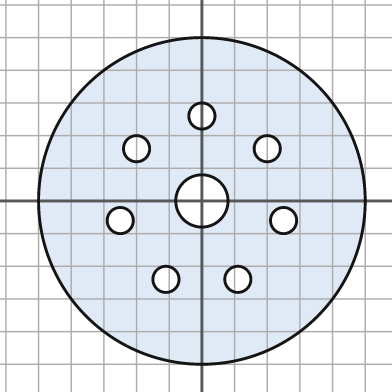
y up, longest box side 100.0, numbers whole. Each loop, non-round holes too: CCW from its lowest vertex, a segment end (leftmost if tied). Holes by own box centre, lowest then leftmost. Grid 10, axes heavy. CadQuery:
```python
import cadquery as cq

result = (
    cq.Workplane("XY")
    .moveTo(0.0, 0.0)
    .circle(50.0)
    .moveTo(-11.0, -24.0)
    .circle(4.0)
    .moveTo(11.0, -24.0)
    .circle(4.0)
    .moveTo(-25.0, -6.0)
    .circle(4.0)
    .moveTo(25.0, -6.0)
    .circle(4.0)
    .moveTo(0.0, 0.0)
    .circle(8.0)
    .moveTo(-20.0, 16.0)
    .circle(4.0)
    .moveTo(20.0, 16.0)
    .circle(4.0)
    .moveTo(0.0, 26.0)
    .circle(4.0)
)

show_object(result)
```